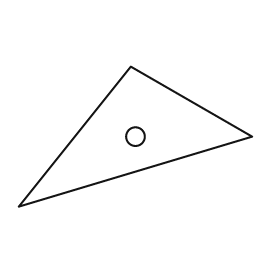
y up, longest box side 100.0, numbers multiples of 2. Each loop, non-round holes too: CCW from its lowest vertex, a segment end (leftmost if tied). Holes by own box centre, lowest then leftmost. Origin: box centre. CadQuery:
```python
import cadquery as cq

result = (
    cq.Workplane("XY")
    .moveTo(-50.0, -30.0)
    .lineTo(50.0, 0.0)
    .lineTo(-2.0, 30.0)
    .close()
    .moveTo(0.0, 0.0)
    .circle(4.0)
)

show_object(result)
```